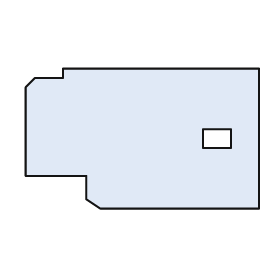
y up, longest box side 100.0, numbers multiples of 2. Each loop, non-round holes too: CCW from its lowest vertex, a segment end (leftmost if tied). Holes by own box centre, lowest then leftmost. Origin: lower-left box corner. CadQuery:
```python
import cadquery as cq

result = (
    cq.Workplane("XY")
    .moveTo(32.0, 0.0)
    .lineTo(100.0, 0.0)
    .lineTo(100.0, 60.0)
    .lineTo(16.0, 60.0)
    .lineTo(16.0, 56.0)
    .lineTo(4.0, 56.0)
    .lineTo(0.0, 52.0)
    .lineTo(0.0, 14.0)
    .lineTo(26.0, 14.0)
    .lineTo(26.0, 4.0)
    .close()
    .moveTo(76.0, 26.0)
    .lineTo(88.0, 26.0)
    .lineTo(88.0, 34.0)
    .lineTo(76.0, 34.0)
    .close()
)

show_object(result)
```